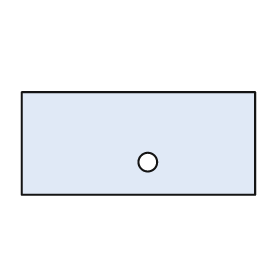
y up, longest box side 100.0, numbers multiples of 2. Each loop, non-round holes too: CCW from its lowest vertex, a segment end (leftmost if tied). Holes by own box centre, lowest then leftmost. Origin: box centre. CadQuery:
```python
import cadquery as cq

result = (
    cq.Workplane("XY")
    .moveTo(-50.0, -22.0)
    .lineTo(50.0, -22.0)
    .lineTo(50.0, 22.0)
    .lineTo(-50.0, 22.0)
    .close()
    .moveTo(4.0, -8.0)
    .circle(4.0)
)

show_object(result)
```